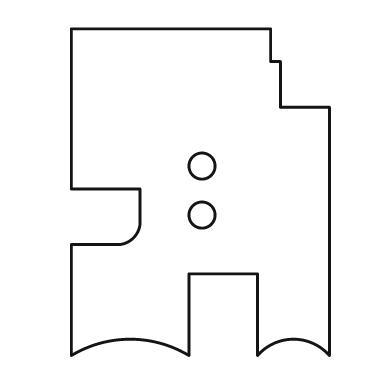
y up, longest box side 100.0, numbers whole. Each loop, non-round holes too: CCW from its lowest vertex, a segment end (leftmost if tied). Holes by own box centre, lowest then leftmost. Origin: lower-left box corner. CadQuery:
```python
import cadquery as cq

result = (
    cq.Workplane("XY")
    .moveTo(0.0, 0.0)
    .threePointArc((18.0, 5.0), (36.0, 0.0))
    .lineTo(36.0, 25.0)
    .lineTo(57.0, 25.0)
    .lineTo(57.0, 0.0)
    .threePointArc((68.0, 5.0), (79.0, 0.0))
    .lineTo(79.0, 76.0)
    .lineTo(64.0, 76.0)
    .lineTo(64.0, 90.0)
    .lineTo(61.0, 90.0)
    .lineTo(61.0, 100.0)
    .lineTo(0.0, 100.0)
    .lineTo(0.0, 51.0)
    .lineTo(21.0, 51.0)
    .lineTo(21.0, 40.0)
    .threePointArc((19.0, 36.0), (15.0, 34.0))
    .lineTo(0.0, 34.0)
    .close()
    .moveTo(40.0, 43.0)
    .circle(4.0)
    .moveTo(40.0, 58.0)
    .circle(4.0)
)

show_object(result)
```